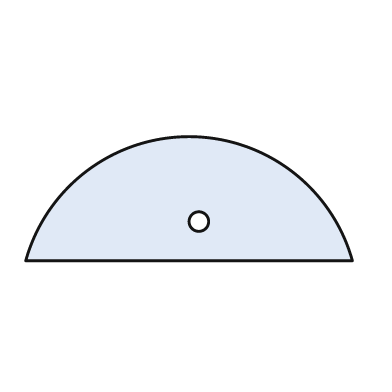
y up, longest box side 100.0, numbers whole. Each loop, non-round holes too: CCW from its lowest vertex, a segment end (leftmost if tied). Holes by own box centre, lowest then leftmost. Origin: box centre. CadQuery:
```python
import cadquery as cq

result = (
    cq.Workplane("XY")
    .moveTo(-50.0, -19.0)
    .lineTo(50.0, -19.0)
    .threePointArc((0.0, 19.0), (-50.0, -19.0))
    .close()
    .moveTo(3.0, -7.0)
    .circle(3.0)
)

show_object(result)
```